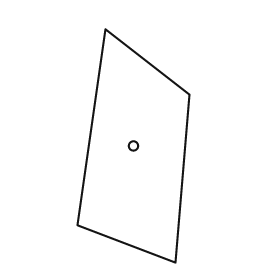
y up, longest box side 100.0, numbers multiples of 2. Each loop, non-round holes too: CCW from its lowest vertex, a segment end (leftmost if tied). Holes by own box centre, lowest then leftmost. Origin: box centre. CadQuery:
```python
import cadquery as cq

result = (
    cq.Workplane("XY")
    .moveTo(18.0, -50.0)
    .lineTo(24.0, 22.0)
    .lineTo(-12.0, 50.0)
    .lineTo(-24.0, -34.0)
    .close()
    .moveTo(0.0, 0.0)
    .circle(2.0)
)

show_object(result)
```